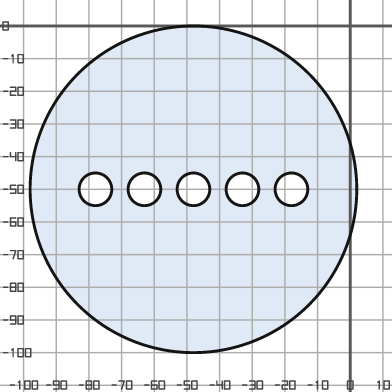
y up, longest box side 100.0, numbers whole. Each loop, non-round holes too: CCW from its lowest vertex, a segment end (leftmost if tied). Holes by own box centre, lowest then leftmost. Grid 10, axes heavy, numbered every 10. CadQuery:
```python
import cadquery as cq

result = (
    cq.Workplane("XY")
    .moveTo(-48.0, -50.0)
    .circle(50.0)
    .moveTo(-78.0, -50.0)
    .circle(5.0)
    .moveTo(-63.0, -50.0)
    .circle(5.0)
    .moveTo(-48.0, -50.0)
    .circle(5.0)
    .moveTo(-33.0, -50.0)
    .circle(5.0)
    .moveTo(-18.0, -50.0)
    .circle(5.0)
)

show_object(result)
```